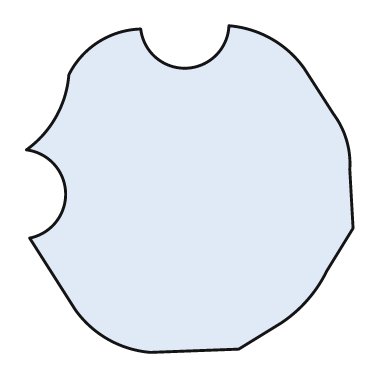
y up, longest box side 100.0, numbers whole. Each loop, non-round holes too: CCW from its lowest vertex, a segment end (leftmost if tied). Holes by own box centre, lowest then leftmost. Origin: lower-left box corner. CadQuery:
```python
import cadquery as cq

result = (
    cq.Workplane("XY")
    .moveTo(38.0, 0.0)
    .lineTo(65.0, 1.0)
    .lineTo(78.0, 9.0)
    .threePointArc((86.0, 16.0), (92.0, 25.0))
    .lineTo(100.0, 38.0)
    .lineTo(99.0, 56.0)
    .threePointArc((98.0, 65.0), (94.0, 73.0))
    .lineTo(85.0, 87.0)
    .threePointArc((75.0, 96.0), (62.0, 100.0))
    .threePointArc((49.0, 87.0), (35.0, 99.0))
    .threePointArc((22.0, 95.0), (13.0, 85.0))
    .threePointArc((9.0, 72.0), (0.0, 62.0))
    .threePointArc((12.0, 49.0), (1.0, 35.0))
    .lineTo(15.0, 13.0)
    .threePointArc((25.0, 4.0), (38.0, 0.0))
    .close()
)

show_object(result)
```